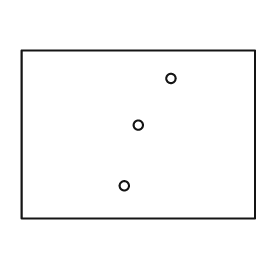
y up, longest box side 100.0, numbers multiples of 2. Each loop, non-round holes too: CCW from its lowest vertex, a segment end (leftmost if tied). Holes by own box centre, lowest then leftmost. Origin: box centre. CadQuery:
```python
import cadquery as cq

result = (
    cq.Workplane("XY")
    .moveTo(-50.0, -36.0)
    .lineTo(50.0, -36.0)
    .lineTo(50.0, 36.0)
    .lineTo(-50.0, 36.0)
    .close()
    .moveTo(-6.0, -22.0)
    .circle(2.0)
    .moveTo(0.0, 4.0)
    .circle(2.0)
    .moveTo(14.0, 24.0)
    .circle(2.0)
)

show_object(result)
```